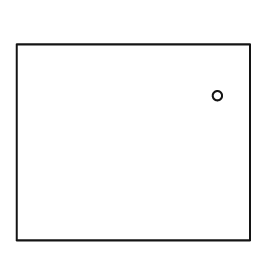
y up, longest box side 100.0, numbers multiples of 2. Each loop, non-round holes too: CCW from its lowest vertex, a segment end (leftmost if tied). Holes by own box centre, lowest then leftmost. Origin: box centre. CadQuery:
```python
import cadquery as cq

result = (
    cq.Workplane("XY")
    .moveTo(-50.0, -42.0)
    .lineTo(50.0, -42.0)
    .lineTo(50.0, 42.0)
    .lineTo(-50.0, 42.0)
    .close()
    .moveTo(36.0, 20.0)
    .circle(2.0)
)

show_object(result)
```